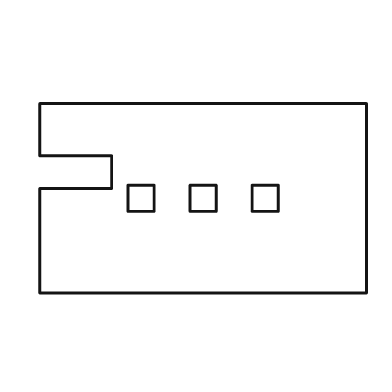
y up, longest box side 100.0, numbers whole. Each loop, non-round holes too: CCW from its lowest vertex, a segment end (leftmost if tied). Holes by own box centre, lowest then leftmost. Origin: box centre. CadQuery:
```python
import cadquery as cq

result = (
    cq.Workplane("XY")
    .moveTo(-50.0, -29.0)
    .lineTo(50.0, -29.0)
    .lineTo(50.0, 29.0)
    .lineTo(-50.0, 29.0)
    .lineTo(-50.0, 13.0)
    .lineTo(-28.0, 13.0)
    .lineTo(-28.0, 3.0)
    .lineTo(-50.0, 3.0)
    .close()
    .moveTo(-23.0, -4.0)
    .lineTo(-15.0, -4.0)
    .lineTo(-15.0, 4.0)
    .lineTo(-23.0, 4.0)
    .close()
    .moveTo(-4.0, -4.0)
    .lineTo(4.0, -4.0)
    .lineTo(4.0, 4.0)
    .lineTo(-4.0, 4.0)
    .close()
    .moveTo(15.0, -4.0)
    .lineTo(23.0, -4.0)
    .lineTo(23.0, 4.0)
    .lineTo(15.0, 4.0)
    .close()
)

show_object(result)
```